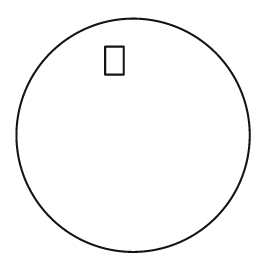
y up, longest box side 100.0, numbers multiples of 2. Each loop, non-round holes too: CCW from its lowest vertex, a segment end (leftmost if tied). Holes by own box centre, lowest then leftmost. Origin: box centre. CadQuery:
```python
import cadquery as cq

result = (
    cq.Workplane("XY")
    .moveTo(0.0, 0.0)
    .circle(50.0)
    .moveTo(-12.0, 26.0)
    .lineTo(-4.0, 26.0)
    .lineTo(-4.0, 38.0)
    .lineTo(-12.0, 38.0)
    .close()
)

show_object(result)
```